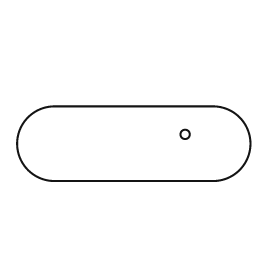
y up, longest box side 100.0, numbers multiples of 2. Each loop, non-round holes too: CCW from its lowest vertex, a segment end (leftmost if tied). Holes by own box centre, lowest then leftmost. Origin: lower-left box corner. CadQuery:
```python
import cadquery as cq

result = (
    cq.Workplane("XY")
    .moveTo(16.0, 0.0)
    .lineTo(84.0, 0.0)
    .threePointArc((100.0, 16.0), (84.0, 32.0))
    .lineTo(16.0, 32.0)
    .threePointArc((0.0, 16.0), (16.0, 0.0))
    .close()
    .moveTo(72.0, 20.0)
    .circle(2.0)
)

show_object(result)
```